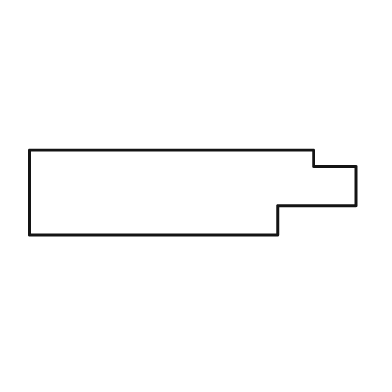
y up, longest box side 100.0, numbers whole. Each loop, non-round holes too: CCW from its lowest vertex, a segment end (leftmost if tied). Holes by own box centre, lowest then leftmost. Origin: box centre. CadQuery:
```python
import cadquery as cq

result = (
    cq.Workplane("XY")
    .moveTo(-50.0, -13.0)
    .lineTo(26.0, -13.0)
    .lineTo(26.0, -4.0)
    .lineTo(50.0, -4.0)
    .lineTo(50.0, 8.0)
    .lineTo(37.0, 8.0)
    .lineTo(37.0, 13.0)
    .lineTo(-50.0, 13.0)
    .close()
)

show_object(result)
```